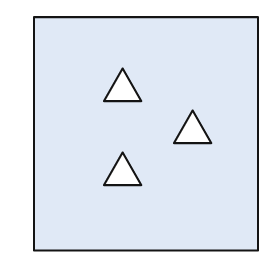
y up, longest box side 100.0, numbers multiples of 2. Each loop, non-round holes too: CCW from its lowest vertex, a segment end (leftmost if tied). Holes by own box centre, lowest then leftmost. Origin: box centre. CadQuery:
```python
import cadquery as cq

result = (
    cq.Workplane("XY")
    .moveTo(-48.0, -50.0)
    .lineTo(48.0, -50.0)
    .lineTo(48.0, 50.0)
    .lineTo(-48.0, 50.0)
    .close()
    .moveTo(-18.0, -22.0)
    .lineTo(-2.0, -22.0)
    .lineTo(-10.0, -8.0)
    .close()
    .moveTo(12.0, -4.0)
    .lineTo(28.0, -4.0)
    .lineTo(20.0, 10.0)
    .close()
    .moveTo(-18.0, 14.0)
    .lineTo(-2.0, 14.0)
    .lineTo(-10.0, 28.0)
    .close()
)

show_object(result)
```